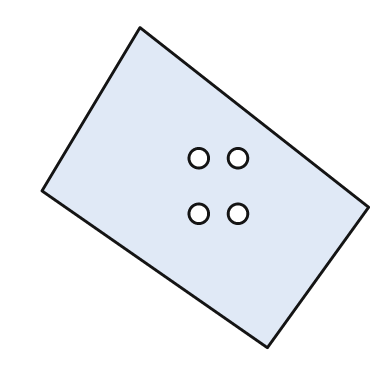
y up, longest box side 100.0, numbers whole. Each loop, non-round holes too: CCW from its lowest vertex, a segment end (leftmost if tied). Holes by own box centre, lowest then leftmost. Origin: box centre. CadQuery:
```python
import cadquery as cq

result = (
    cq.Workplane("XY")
    .moveTo(19.0, -49.0)
    .lineTo(50.0, -6.0)
    .lineTo(-20.0, 49.0)
    .lineTo(-50.0, -1.0)
    .close()
    .moveTo(-2.0, -8.0)
    .circle(3.0)
    .moveTo(10.0, -8.0)
    .circle(3.0)
    .moveTo(-2.0, 9.0)
    .circle(3.0)
    .moveTo(10.0, 9.0)
    .circle(3.0)
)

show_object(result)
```